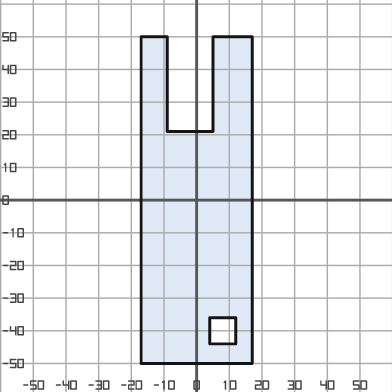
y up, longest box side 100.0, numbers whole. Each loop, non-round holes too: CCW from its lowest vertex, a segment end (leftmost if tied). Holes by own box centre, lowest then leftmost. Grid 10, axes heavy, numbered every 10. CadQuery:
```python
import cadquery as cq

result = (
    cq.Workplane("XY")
    .moveTo(-17.0, -50.0)
    .lineTo(17.0, -50.0)
    .lineTo(17.0, 50.0)
    .lineTo(5.0, 50.0)
    .lineTo(5.0, 21.0)
    .lineTo(-9.0, 21.0)
    .lineTo(-9.0, 50.0)
    .lineTo(-17.0, 50.0)
    .close()
    .moveTo(4.0, -44.0)
    .lineTo(12.0, -44.0)
    .lineTo(12.0, -36.0)
    .lineTo(4.0, -36.0)
    .close()
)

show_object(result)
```